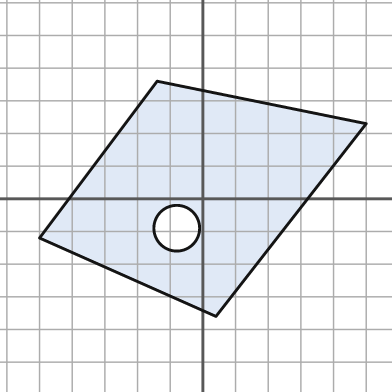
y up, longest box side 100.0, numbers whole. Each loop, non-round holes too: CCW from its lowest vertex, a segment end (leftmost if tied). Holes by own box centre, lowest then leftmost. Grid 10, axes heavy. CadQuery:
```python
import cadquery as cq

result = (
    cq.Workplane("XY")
    .moveTo(4.0, -36.0)
    .lineTo(50.0, 23.0)
    .lineTo(-14.0, 36.0)
    .lineTo(-50.0, -12.0)
    .close()
    .moveTo(-8.0, -9.0)
    .circle(7.0)
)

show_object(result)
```